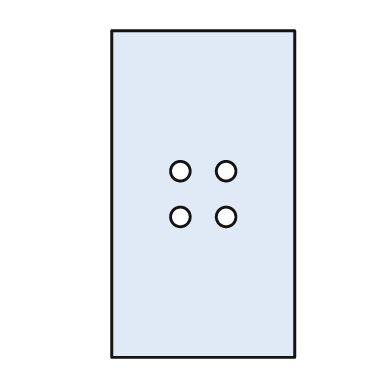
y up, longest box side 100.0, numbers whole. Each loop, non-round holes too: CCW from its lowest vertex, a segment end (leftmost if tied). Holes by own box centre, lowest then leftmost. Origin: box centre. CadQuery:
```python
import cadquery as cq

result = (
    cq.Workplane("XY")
    .moveTo(-28.0, -50.0)
    .lineTo(28.0, -50.0)
    .lineTo(28.0, 50.0)
    .lineTo(-28.0, 50.0)
    .close()
    .moveTo(-7.0, -7.0)
    .circle(3.0)
    .moveTo(7.0, -7.0)
    .circle(3.0)
    .moveTo(-7.0, 7.0)
    .circle(3.0)
    .moveTo(7.0, 7.0)
    .circle(3.0)
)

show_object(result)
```